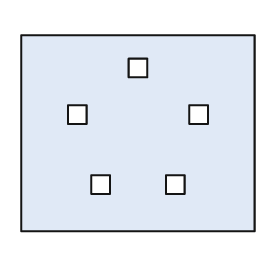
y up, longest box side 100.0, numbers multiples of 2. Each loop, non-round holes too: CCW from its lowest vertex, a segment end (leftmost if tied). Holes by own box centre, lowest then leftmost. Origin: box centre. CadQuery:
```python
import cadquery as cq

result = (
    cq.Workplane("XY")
    .moveTo(-50.0, -42.0)
    .lineTo(50.0, -42.0)
    .lineTo(50.0, 42.0)
    .lineTo(-50.0, 42.0)
    .close()
    .moveTo(-20.0, -26.0)
    .lineTo(-12.0, -26.0)
    .lineTo(-12.0, -18.0)
    .lineTo(-20.0, -18.0)
    .close()
    .moveTo(12.0, -26.0)
    .lineTo(20.0, -26.0)
    .lineTo(20.0, -18.0)
    .lineTo(12.0, -18.0)
    .close()
    .moveTo(-30.0, 4.0)
    .lineTo(-22.0, 4.0)
    .lineTo(-22.0, 12.0)
    .lineTo(-30.0, 12.0)
    .close()
    .moveTo(22.0, 4.0)
    .lineTo(30.0, 4.0)
    .lineTo(30.0, 12.0)
    .lineTo(22.0, 12.0)
    .close()
    .moveTo(-4.0, 24.0)
    .lineTo(4.0, 24.0)
    .lineTo(4.0, 32.0)
    .lineTo(-4.0, 32.0)
    .close()
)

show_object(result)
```